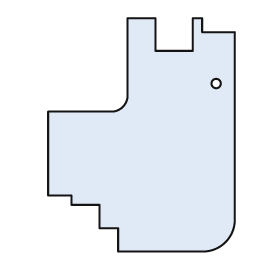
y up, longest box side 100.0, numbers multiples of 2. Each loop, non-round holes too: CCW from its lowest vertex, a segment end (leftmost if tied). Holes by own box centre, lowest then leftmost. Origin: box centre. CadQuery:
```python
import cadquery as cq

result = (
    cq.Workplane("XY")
    .moveTo(-10.0, -50.0)
    .lineTo(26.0, -50.0)
    .threePointArc((36.0, -46.0), (40.0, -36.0))
    .lineTo(40.0, 44.0)
    .lineTo(26.0, 44.0)
    .lineTo(26.0, 50.0)
    .lineTo(22.0, 50.0)
    .lineTo(22.0, 36.0)
    .lineTo(6.0, 36.0)
    .lineTo(6.0, 50.0)
    .lineTo(-6.0, 50.0)
    .lineTo(-6.0, 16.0)
    .threePointArc((-8.0, 12.0), (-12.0, 10.0))
    .lineTo(-40.0, 10.0)
    .lineTo(-40.0, -26.0)
    .lineTo(-30.0, -26.0)
    .lineTo(-30.0, -30.0)
    .lineTo(-18.0, -30.0)
    .lineTo(-18.0, -40.0)
    .lineTo(-10.0, -40.0)
    .close()
    .moveTo(32.0, 22.0)
    .circle(2.0)
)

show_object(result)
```